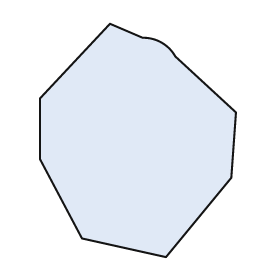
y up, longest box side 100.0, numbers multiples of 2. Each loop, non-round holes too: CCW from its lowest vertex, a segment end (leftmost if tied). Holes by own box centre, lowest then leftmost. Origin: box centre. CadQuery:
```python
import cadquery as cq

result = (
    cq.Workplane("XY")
    .moveTo(12.0, -50.0)
    .lineTo(40.0, -16.0)
    .lineTo(42.0, 12.0)
    .lineTo(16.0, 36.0)
    .threePointArc((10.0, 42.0), (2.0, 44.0))
    .lineTo(-12.0, 50.0)
    .lineTo(-42.0, 18.0)
    .lineTo(-42.0, -8.0)
    .lineTo(-24.0, -42.0)
    .close()
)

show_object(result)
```